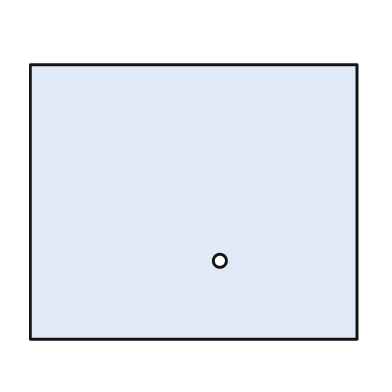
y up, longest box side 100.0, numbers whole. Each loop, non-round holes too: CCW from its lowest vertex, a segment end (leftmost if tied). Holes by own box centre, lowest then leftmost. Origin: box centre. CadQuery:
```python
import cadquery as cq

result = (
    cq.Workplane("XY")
    .moveTo(-50.0, -42.0)
    .lineTo(50.0, -42.0)
    .lineTo(50.0, 42.0)
    .lineTo(-50.0, 42.0)
    .close()
    .moveTo(8.0, -18.0)
    .circle(2.0)
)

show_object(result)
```